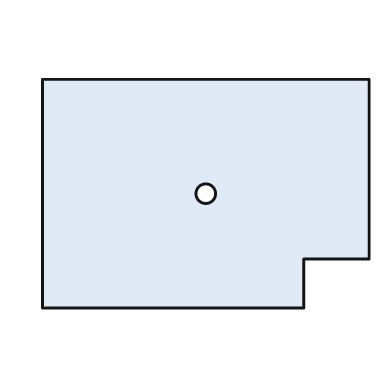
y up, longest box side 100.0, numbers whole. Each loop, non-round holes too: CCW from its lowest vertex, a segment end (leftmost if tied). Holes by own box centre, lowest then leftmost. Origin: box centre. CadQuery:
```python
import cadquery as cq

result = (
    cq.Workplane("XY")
    .moveTo(-50.0, -35.0)
    .lineTo(30.0, -35.0)
    .lineTo(30.0, -20.0)
    .lineTo(50.0, -20.0)
    .lineTo(50.0, 35.0)
    .lineTo(-50.0, 35.0)
    .close()
    .moveTo(0.0, 0.0)
    .circle(3.0)
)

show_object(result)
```